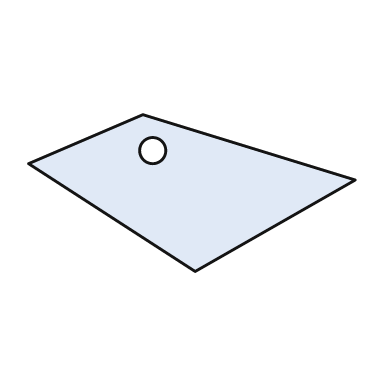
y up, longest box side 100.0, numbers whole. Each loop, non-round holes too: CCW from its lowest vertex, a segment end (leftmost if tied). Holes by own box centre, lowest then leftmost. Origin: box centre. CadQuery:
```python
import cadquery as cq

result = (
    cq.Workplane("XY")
    .moveTo(1.0, -24.0)
    .lineTo(50.0, 4.0)
    .lineTo(-15.0, 24.0)
    .lineTo(-50.0, 9.0)
    .close()
    .moveTo(-12.0, 13.0)
    .circle(4.0)
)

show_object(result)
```